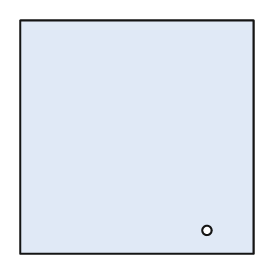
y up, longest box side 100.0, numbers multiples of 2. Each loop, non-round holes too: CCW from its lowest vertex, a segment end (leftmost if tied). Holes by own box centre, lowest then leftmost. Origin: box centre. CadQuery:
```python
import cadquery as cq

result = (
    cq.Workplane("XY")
    .moveTo(-50.0, -50.0)
    .lineTo(50.0, -50.0)
    .lineTo(50.0, 50.0)
    .lineTo(-50.0, 50.0)
    .close()
    .moveTo(30.0, -40.0)
    .circle(2.0)
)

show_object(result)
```